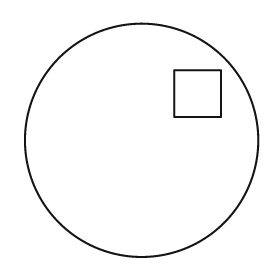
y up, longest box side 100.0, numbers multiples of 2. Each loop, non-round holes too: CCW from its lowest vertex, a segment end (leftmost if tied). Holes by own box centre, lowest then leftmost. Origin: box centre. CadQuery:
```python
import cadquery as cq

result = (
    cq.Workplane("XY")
    .moveTo(0.0, 0.0)
    .circle(50.0)
    .moveTo(14.0, 10.0)
    .lineTo(34.0, 10.0)
    .lineTo(34.0, 30.0)
    .lineTo(14.0, 30.0)
    .close()
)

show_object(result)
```